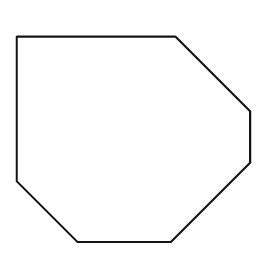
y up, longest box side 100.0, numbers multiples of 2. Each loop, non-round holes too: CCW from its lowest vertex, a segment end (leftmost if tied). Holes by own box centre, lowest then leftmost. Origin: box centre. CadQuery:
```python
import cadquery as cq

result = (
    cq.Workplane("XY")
    .moveTo(-24.0, -44.0)
    .lineTo(16.0, -44.0)
    .lineTo(50.0, -10.0)
    .lineTo(50.0, 12.0)
    .lineTo(18.0, 44.0)
    .lineTo(-50.0, 44.0)
    .lineTo(-50.0, -18.0)
    .close()
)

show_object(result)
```